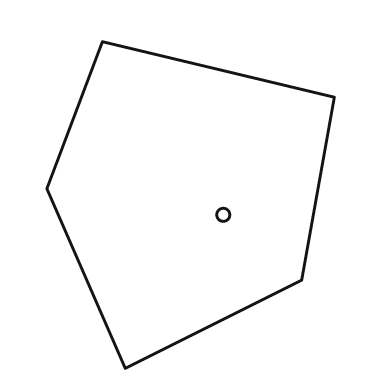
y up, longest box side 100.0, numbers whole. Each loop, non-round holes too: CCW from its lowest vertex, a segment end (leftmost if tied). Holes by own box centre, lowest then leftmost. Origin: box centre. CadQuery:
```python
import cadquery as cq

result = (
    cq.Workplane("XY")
    .moveTo(-20.0, -50.0)
    .lineTo(34.0, -23.0)
    .lineTo(44.0, 33.0)
    .lineTo(-27.0, 50.0)
    .lineTo(-44.0, 5.0)
    .close()
    .moveTo(10.0, -3.0)
    .circle(2.0)
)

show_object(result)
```